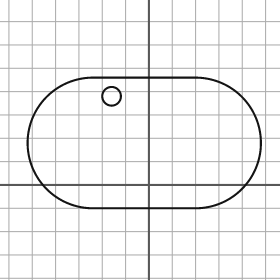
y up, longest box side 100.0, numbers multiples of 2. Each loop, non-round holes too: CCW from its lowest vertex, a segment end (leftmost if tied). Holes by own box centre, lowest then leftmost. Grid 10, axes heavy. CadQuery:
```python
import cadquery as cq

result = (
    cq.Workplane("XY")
    .moveTo(-24.0, -10.0)
    .lineTo(20.0, -10.0)
    .threePointArc((48.0, 18.0), (20.0, 46.0))
    .lineTo(-24.0, 46.0)
    .threePointArc((-52.0, 18.0), (-24.0, -10.0))
    .close()
    .moveTo(-16.0, 38.0)
    .circle(4.0)
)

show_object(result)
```